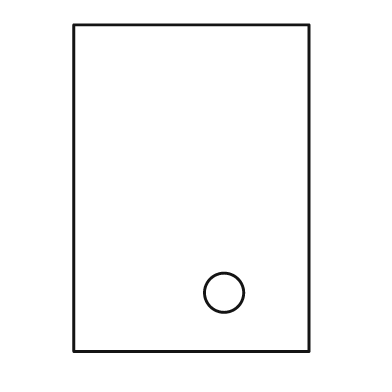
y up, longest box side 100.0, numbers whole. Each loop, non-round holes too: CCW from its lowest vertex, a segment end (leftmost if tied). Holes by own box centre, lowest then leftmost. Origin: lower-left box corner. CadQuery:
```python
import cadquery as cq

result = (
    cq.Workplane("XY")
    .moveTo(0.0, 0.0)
    .lineTo(72.0, 0.0)
    .lineTo(72.0, 100.0)
    .lineTo(0.0, 100.0)
    .close()
    .moveTo(46.0, 18.0)
    .circle(6.0)
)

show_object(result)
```